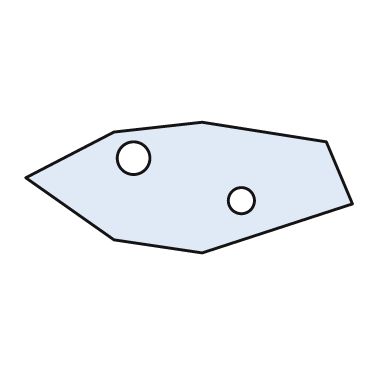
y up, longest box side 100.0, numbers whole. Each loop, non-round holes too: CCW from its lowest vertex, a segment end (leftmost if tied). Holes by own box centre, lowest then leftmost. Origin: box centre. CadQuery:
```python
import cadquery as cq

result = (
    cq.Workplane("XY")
    .moveTo(4.0, -20.0)
    .lineTo(50.0, -5.0)
    .lineTo(42.0, 14.0)
    .lineTo(4.0, 20.0)
    .lineTo(-23.0, 17.0)
    .lineTo(-50.0, 3.0)
    .lineTo(-23.0, -16.0)
    .close()
    .moveTo(16.0, -4.0)
    .circle(4.0)
    .moveTo(-17.0, 9.0)
    .circle(5.0)
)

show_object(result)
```